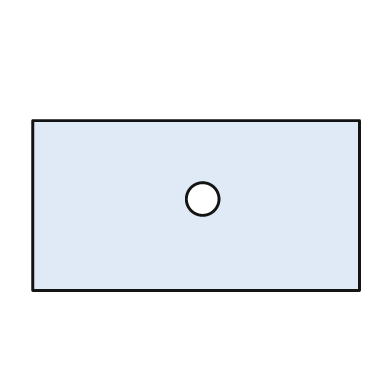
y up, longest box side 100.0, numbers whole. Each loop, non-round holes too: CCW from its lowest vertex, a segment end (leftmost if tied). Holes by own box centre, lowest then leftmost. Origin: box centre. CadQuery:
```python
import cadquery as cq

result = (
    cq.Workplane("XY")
    .moveTo(-50.0, -26.0)
    .lineTo(50.0, -26.0)
    .lineTo(50.0, 26.0)
    .lineTo(-50.0, 26.0)
    .close()
    .moveTo(2.0, 2.0)
    .circle(5.0)
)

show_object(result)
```